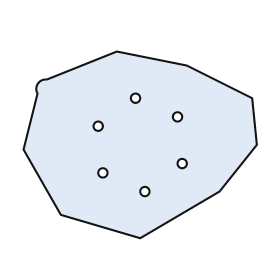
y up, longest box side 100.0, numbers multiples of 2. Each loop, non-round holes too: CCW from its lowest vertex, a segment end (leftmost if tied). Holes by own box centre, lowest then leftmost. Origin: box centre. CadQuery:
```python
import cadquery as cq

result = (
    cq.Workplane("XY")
    .moveTo(0.0, -40.0)
    .lineTo(34.0, -20.0)
    .lineTo(50.0, 0.0)
    .lineTo(48.0, 20.0)
    .lineTo(20.0, 34.0)
    .lineTo(-10.0, 40.0)
    .lineTo(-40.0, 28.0)
    .threePointArc((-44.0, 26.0), (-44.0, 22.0))
    .lineTo(-50.0, -2.0)
    .lineTo(-34.0, -30.0)
    .close()
    .moveTo(2.0, -20.0)
    .circle(2.0)
    .moveTo(-16.0, -12.0)
    .circle(2.0)
    .moveTo(18.0, -8.0)
    .circle(2.0)
    .moveTo(-18.0, 8.0)
    .circle(2.0)
    .moveTo(16.0, 12.0)
    .circle(2.0)
    .moveTo(-2.0, 20.0)
    .circle(2.0)
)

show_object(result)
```